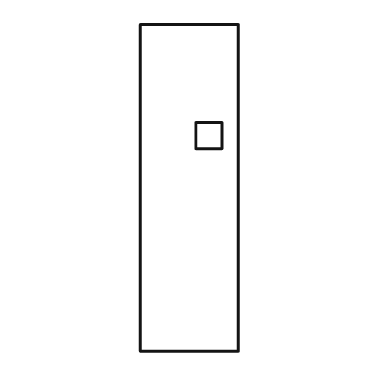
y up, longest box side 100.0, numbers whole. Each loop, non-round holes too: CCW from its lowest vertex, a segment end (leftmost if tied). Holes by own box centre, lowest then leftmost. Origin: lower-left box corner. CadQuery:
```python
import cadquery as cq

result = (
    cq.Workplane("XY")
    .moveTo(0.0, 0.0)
    .lineTo(30.0, 0.0)
    .lineTo(30.0, 100.0)
    .lineTo(0.0, 100.0)
    .close()
    .moveTo(17.0, 62.0)
    .lineTo(25.0, 62.0)
    .lineTo(25.0, 70.0)
    .lineTo(17.0, 70.0)
    .close()
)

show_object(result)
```